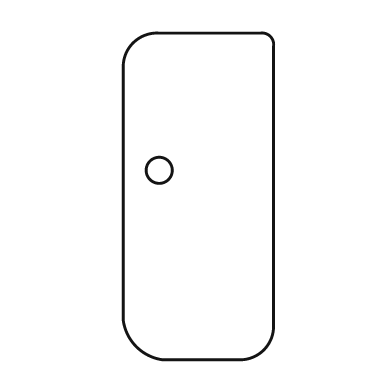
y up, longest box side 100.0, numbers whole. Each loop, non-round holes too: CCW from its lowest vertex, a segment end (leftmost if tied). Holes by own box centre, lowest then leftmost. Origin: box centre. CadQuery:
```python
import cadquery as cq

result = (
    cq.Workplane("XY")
    .moveTo(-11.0, -50.0)
    .lineTo(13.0, -50.0)
    .threePointArc((20.0, -47.0), (23.0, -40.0))
    .lineTo(23.0, 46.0)
    .threePointArc((22.0, 49.0), (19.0, 50.0))
    .lineTo(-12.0, 50.0)
    .threePointArc((-20.0, 47.0), (-23.0, 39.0))
    .lineTo(-23.0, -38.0)
    .threePointArc((-19.0, -46.0), (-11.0, -50.0))
    .close()
    .moveTo(-12.0, 8.0)
    .circle(4.0)
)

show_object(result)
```